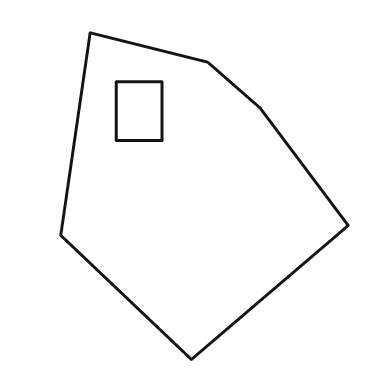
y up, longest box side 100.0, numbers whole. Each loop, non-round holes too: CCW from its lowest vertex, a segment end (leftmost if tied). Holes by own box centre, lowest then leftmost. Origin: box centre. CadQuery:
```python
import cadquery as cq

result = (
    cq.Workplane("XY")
    .moveTo(-4.0, -50.0)
    .lineTo(44.0, -9.0)
    .lineTo(17.0, 27.0)
    .lineTo(1.0, 41.0)
    .lineTo(-35.0, 50.0)
    .lineTo(-44.0, -12.0)
    .close()
    .moveTo(-27.0, 17.0)
    .lineTo(-13.0, 17.0)
    .lineTo(-13.0, 35.0)
    .lineTo(-27.0, 35.0)
    .close()
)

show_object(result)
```